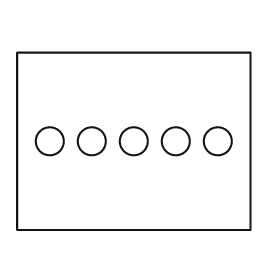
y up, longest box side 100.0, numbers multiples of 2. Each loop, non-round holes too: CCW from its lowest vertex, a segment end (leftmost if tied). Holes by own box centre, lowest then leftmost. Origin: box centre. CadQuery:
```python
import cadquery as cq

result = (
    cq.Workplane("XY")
    .moveTo(-50.0, -38.0)
    .lineTo(50.0, -38.0)
    .lineTo(50.0, 38.0)
    .lineTo(-50.0, 38.0)
    .close()
    .moveTo(-36.0, 0.0)
    .circle(6.0)
    .moveTo(-18.0, 0.0)
    .circle(6.0)
    .moveTo(0.0, 0.0)
    .circle(6.0)
    .moveTo(18.0, 0.0)
    .circle(6.0)
    .moveTo(36.0, 0.0)
    .circle(6.0)
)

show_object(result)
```